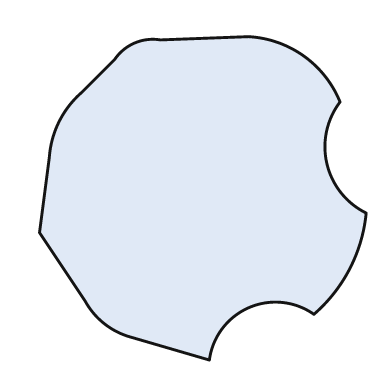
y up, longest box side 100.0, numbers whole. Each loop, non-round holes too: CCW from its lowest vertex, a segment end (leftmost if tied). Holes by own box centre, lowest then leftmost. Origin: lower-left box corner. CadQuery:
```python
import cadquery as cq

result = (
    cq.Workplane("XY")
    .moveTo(52.0, 0.0)
    .threePointArc((64.0, 16.0), (84.0, 14.0))
    .threePointArc((95.0, 28.0), (100.0, 45.0))
    .threePointArc((88.0, 60.0), (92.0, 79.0))
    .threePointArc((81.0, 93.0), (64.0, 99.0))
    .lineTo(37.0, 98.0)
    .threePointArc((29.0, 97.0), (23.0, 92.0))
    .lineTo(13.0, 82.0)
    .threePointArc((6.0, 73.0), (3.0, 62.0))
    .lineTo(0.0, 39.0)
    .lineTo(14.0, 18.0)
    .threePointArc((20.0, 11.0), (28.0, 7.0))
    .close()
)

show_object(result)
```